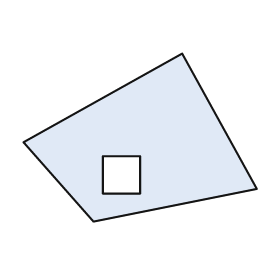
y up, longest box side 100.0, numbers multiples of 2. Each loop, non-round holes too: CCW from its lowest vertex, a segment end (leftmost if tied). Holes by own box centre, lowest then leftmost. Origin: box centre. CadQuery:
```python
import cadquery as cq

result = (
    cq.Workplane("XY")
    .moveTo(-20.0, -36.0)
    .lineTo(50.0, -22.0)
    .lineTo(18.0, 36.0)
    .lineTo(-50.0, -2.0)
    .close()
    .moveTo(-16.0, -24.0)
    .lineTo(0.0, -24.0)
    .lineTo(0.0, -8.0)
    .lineTo(-16.0, -8.0)
    .close()
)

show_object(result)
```